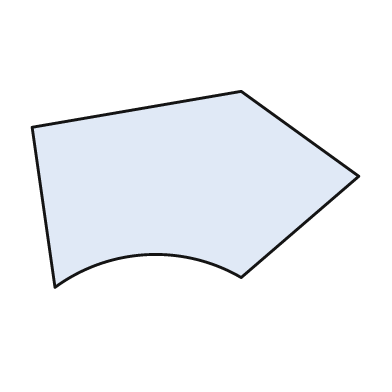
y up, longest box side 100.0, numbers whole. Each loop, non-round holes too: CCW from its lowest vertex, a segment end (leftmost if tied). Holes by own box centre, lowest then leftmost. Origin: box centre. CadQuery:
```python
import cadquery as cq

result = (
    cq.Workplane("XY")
    .moveTo(-43.0, -30.0)
    .threePointArc((-15.0, -20.0), (14.0, -27.0))
    .lineTo(50.0, 4.0)
    .lineTo(14.0, 30.0)
    .lineTo(-50.0, 19.0)
    .close()
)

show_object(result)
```